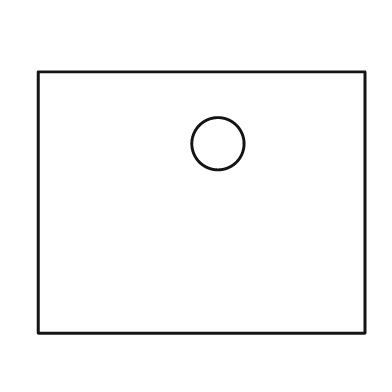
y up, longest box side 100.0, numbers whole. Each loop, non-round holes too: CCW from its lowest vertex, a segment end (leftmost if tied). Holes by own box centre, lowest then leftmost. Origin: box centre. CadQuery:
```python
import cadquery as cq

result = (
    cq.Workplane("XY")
    .moveTo(-50.0, -40.0)
    .lineTo(50.0, -40.0)
    .lineTo(50.0, 40.0)
    .lineTo(-50.0, 40.0)
    .close()
    .moveTo(5.0, 18.0)
    .circle(8.0)
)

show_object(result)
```